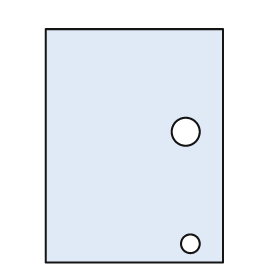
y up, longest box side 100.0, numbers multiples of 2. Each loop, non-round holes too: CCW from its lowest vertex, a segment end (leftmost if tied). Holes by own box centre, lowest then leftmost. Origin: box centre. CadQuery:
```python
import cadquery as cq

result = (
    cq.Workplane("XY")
    .moveTo(-38.0, -50.0)
    .lineTo(38.0, -50.0)
    .lineTo(38.0, 50.0)
    .lineTo(-38.0, 50.0)
    .close()
    .moveTo(24.0, -42.0)
    .circle(4.0)
    .moveTo(22.0, 6.0)
    .circle(6.0)
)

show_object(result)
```